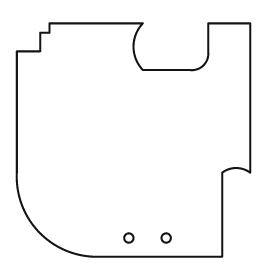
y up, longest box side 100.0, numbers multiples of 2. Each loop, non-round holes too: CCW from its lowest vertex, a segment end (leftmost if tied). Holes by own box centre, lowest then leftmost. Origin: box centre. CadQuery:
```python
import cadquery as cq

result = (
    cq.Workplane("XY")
    .moveTo(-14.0, -50.0)
    .lineTo(38.0, -50.0)
    .lineTo(38.0, -14.0)
    .threePointArc((44.0, -12.0), (50.0, -14.0))
    .lineTo(50.0, 50.0)
    .lineTo(32.0, 50.0)
    .lineTo(32.0, 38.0)
    .threePointArc((30.0, 32.0), (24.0, 30.0))
    .lineTo(4.0, 30.0)
    .threePointArc((0.0, 40.0), (4.0, 50.0))
    .lineTo(-36.0, 50.0)
    .lineTo(-36.0, 46.0)
    .lineTo(-40.0, 46.0)
    .lineTo(-40.0, 38.0)
    .lineTo(-50.0, 38.0)
    .lineTo(-50.0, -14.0)
    .threePointArc((-40.0, -40.0), (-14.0, -50.0))
    .close()
    .moveTo(-2.0, -42.0)
    .circle(2.0)
    .moveTo(14.0, -42.0)
    .circle(2.0)
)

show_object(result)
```